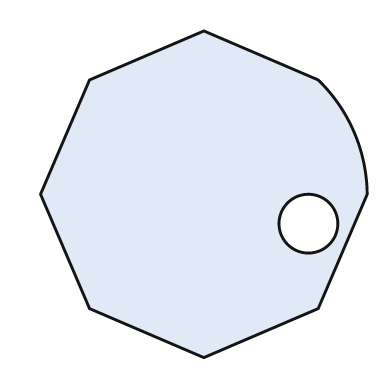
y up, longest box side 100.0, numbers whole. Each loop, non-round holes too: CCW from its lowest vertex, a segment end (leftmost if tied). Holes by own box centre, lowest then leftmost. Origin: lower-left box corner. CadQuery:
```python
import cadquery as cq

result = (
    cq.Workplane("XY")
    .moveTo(50.0, 0.0)
    .lineTo(85.0, 15.0)
    .lineTo(100.0, 50.0)
    .threePointArc((96.0, 69.0), (85.0, 85.0))
    .lineTo(50.0, 100.0)
    .lineTo(15.0, 85.0)
    .lineTo(0.0, 50.0)
    .lineTo(15.0, 15.0)
    .close()
    .moveTo(82.0, 41.0)
    .circle(9.0)
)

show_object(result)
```